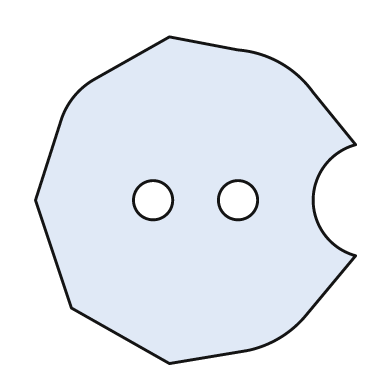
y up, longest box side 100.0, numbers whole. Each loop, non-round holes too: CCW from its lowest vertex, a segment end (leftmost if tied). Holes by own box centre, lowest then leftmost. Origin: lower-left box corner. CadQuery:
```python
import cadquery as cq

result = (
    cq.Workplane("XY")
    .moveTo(41.0, 0.0)
    .lineTo(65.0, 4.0)
    .threePointArc((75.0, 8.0), (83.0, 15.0))
    .lineTo(98.0, 33.0)
    .threePointArc((85.0, 50.0), (98.0, 67.0))
    .lineTo(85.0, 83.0)
    .threePointArc((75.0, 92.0), (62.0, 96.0))
    .lineTo(41.0, 100.0)
    .lineTo(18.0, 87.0)
    .threePointArc((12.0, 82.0), (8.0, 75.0))
    .lineTo(0.0, 50.0)
    .lineTo(11.0, 17.0)
    .close()
    .moveTo(36.0, 50.0)
    .circle(6.0)
    .moveTo(62.0, 50.0)
    .circle(6.0)
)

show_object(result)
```